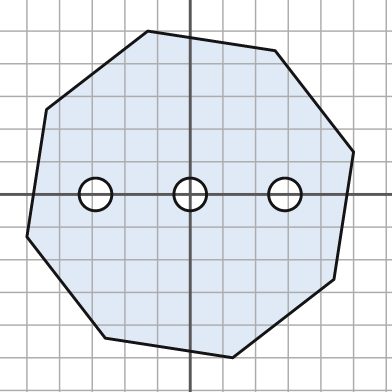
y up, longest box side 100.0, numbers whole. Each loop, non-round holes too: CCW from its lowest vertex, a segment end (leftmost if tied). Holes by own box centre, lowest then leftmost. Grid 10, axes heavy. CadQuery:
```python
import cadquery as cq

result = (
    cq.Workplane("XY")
    .moveTo(13.0, -50.0)
    .lineTo(44.0, -26.0)
    .lineTo(50.0, 13.0)
    .lineTo(26.0, 44.0)
    .lineTo(-13.0, 50.0)
    .lineTo(-44.0, 26.0)
    .lineTo(-50.0, -13.0)
    .lineTo(-26.0, -44.0)
    .close()
    .moveTo(-29.0, 0.0)
    .circle(5.0)
    .moveTo(0.0, 0.0)
    .circle(5.0)
    .moveTo(29.0, 0.0)
    .circle(5.0)
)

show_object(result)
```